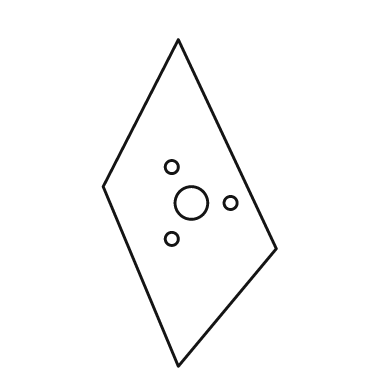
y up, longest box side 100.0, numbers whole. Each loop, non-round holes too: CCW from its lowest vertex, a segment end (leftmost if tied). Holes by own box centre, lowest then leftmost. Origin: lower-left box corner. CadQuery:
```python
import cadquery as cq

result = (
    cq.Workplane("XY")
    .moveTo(23.0, 0.0)
    .lineTo(53.0, 36.0)
    .lineTo(23.0, 100.0)
    .lineTo(0.0, 55.0)
    .close()
    .moveTo(21.0, 39.0)
    .circle(2.0)
    .moveTo(27.0, 50.0)
    .circle(5.0)
    .moveTo(39.0, 50.0)
    .circle(2.0)
    .moveTo(21.0, 61.0)
    .circle(2.0)
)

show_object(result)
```